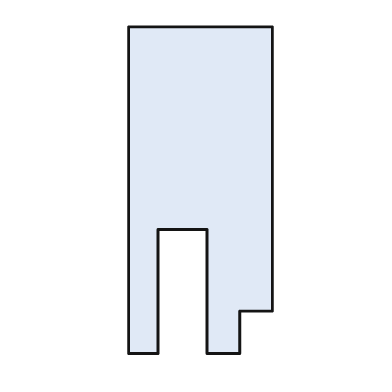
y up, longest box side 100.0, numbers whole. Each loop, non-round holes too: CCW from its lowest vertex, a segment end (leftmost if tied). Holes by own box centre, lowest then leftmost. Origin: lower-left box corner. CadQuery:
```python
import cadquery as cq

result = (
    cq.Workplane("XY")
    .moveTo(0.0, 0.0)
    .lineTo(9.0, 0.0)
    .lineTo(9.0, 38.0)
    .lineTo(24.0, 38.0)
    .lineTo(24.0, 0.0)
    .lineTo(34.0, 0.0)
    .lineTo(34.0, 13.0)
    .lineTo(44.0, 13.0)
    .lineTo(44.0, 100.0)
    .lineTo(0.0, 100.0)
    .close()
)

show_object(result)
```